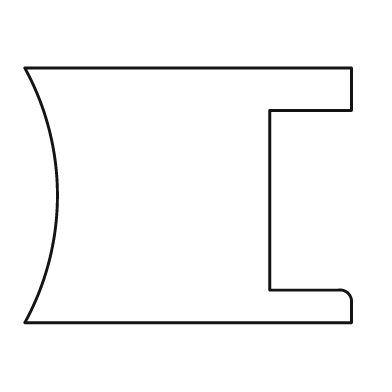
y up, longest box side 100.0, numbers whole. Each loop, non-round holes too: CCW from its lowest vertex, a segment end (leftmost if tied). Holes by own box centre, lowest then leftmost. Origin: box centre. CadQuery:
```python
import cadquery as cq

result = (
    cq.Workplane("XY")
    .moveTo(-50.0, -39.0)
    .lineTo(50.0, -39.0)
    .lineTo(50.0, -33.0)
    .threePointArc((49.0, -30.0), (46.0, -29.0))
    .lineTo(25.0, -29.0)
    .lineTo(25.0, 26.0)
    .lineTo(50.0, 26.0)
    .lineTo(50.0, 39.0)
    .lineTo(-50.0, 39.0)
    .threePointArc((-40.0, 0.0), (-50.0, -39.0))
    .close()
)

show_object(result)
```